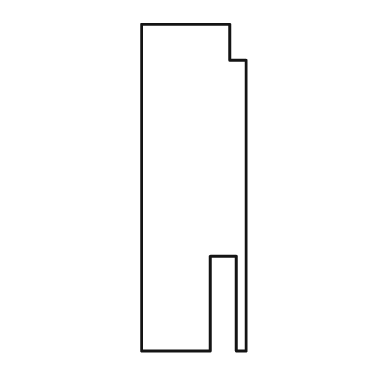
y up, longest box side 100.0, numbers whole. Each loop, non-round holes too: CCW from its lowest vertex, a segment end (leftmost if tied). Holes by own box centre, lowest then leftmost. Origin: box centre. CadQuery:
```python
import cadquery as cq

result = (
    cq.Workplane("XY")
    .moveTo(-16.0, -50.0)
    .lineTo(5.0, -50.0)
    .lineTo(5.0, -21.0)
    .lineTo(13.0, -21.0)
    .lineTo(13.0, -50.0)
    .lineTo(16.0, -50.0)
    .lineTo(16.0, 39.0)
    .lineTo(11.0, 39.0)
    .lineTo(11.0, 50.0)
    .lineTo(-16.0, 50.0)
    .close()
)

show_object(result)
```